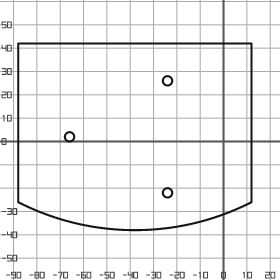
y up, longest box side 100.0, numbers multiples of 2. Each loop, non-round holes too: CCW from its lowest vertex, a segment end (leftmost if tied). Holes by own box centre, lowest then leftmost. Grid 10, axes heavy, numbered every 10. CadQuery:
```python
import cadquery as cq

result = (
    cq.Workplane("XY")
    .moveTo(-88.0, -26.0)
    .threePointArc((-38.0, -38.0), (12.0, -26.0))
    .lineTo(12.0, 42.0)
    .lineTo(-88.0, 42.0)
    .close()
    .moveTo(-24.0, -22.0)
    .circle(2.0)
    .moveTo(-66.0, 2.0)
    .circle(2.0)
    .moveTo(-24.0, 26.0)
    .circle(2.0)
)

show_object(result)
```